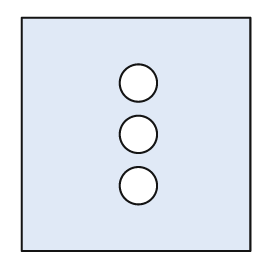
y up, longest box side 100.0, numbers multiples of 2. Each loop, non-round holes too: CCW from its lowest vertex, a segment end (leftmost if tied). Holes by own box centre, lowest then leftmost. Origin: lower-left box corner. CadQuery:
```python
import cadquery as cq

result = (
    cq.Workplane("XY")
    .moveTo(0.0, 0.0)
    .lineTo(98.0, 0.0)
    .lineTo(98.0, 100.0)
    .lineTo(0.0, 100.0)
    .close()
    .moveTo(50.0, 28.0)
    .circle(8.0)
    .moveTo(50.0, 50.0)
    .circle(8.0)
    .moveTo(50.0, 72.0)
    .circle(8.0)
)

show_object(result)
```